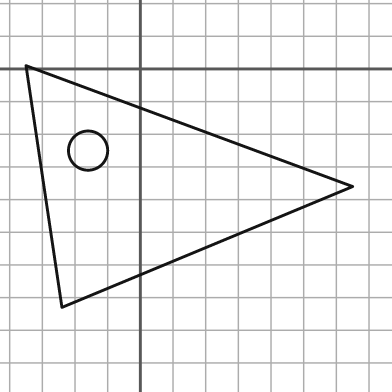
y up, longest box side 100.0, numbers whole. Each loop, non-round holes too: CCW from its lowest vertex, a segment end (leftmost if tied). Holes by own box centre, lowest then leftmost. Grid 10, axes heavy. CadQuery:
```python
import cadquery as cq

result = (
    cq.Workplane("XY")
    .moveTo(-24.0, -73.0)
    .lineTo(65.0, -36.0)
    .lineTo(-35.0, 1.0)
    .close()
    .moveTo(-16.0, -25.0)
    .circle(6.0)
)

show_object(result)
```